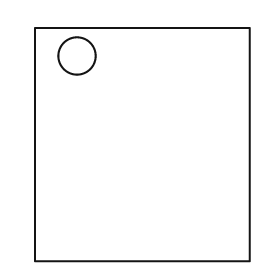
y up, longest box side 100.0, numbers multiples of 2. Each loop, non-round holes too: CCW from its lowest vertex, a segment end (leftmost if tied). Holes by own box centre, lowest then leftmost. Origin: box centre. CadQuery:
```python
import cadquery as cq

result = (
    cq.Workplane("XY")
    .moveTo(-46.0, -50.0)
    .lineTo(46.0, -50.0)
    .lineTo(46.0, 50.0)
    .lineTo(-46.0, 50.0)
    .close()
    .moveTo(-28.0, 38.0)
    .circle(8.0)
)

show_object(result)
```